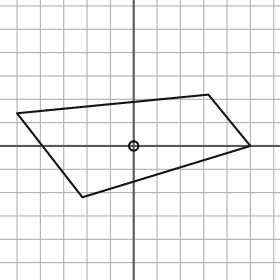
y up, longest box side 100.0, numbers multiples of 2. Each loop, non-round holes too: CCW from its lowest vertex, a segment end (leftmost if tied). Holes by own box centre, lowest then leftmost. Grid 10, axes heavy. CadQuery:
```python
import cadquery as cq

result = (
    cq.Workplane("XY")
    .moveTo(-22.0, -22.0)
    .lineTo(50.0, 0.0)
    .lineTo(32.0, 22.0)
    .lineTo(-50.0, 14.0)
    .close()
    .moveTo(0.0, 0.0)
    .circle(2.0)
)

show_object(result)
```